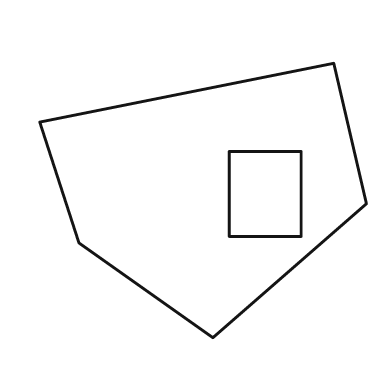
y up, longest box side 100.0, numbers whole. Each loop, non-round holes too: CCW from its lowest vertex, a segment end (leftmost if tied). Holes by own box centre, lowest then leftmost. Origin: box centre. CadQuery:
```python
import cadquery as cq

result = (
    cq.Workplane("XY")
    .moveTo(3.0, -42.0)
    .lineTo(50.0, -1.0)
    .lineTo(40.0, 42.0)
    .lineTo(-50.0, 24.0)
    .lineTo(-38.0, -13.0)
    .close()
    .moveTo(8.0, -11.0)
    .lineTo(30.0, -11.0)
    .lineTo(30.0, 15.0)
    .lineTo(8.0, 15.0)
    .close()
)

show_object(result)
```